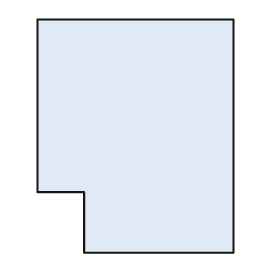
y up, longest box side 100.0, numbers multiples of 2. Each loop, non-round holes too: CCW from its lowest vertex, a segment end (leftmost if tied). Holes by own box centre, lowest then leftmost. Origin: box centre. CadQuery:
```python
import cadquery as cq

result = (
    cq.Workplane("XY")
    .moveTo(-22.0, -50.0)
    .lineTo(42.0, -50.0)
    .lineTo(42.0, 50.0)
    .lineTo(-42.0, 50.0)
    .lineTo(-42.0, -24.0)
    .lineTo(-22.0, -24.0)
    .close()
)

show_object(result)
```